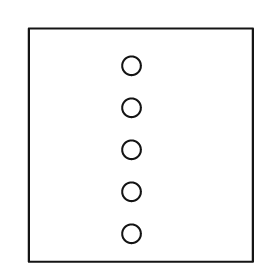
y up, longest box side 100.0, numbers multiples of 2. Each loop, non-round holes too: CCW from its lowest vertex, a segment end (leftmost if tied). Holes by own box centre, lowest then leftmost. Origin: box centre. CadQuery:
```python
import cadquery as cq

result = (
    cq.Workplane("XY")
    .moveTo(-48.0, -50.0)
    .lineTo(48.0, -50.0)
    .lineTo(48.0, 50.0)
    .lineTo(-48.0, 50.0)
    .close()
    .moveTo(-4.0, -38.0)
    .circle(4.0)
    .moveTo(-4.0, -20.0)
    .circle(4.0)
    .moveTo(-4.0, -2.0)
    .circle(4.0)
    .moveTo(-4.0, 16.0)
    .circle(4.0)
    .moveTo(-4.0, 34.0)
    .circle(4.0)
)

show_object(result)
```